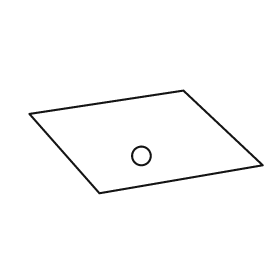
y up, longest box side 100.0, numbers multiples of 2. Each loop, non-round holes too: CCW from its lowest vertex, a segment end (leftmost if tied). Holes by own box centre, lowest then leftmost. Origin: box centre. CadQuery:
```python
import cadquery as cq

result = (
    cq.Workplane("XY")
    .moveTo(-20.0, -22.0)
    .lineTo(50.0, -10.0)
    .lineTo(16.0, 22.0)
    .lineTo(-50.0, 12.0)
    .close()
    .moveTo(-2.0, -6.0)
    .circle(4.0)
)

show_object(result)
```